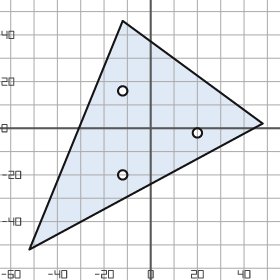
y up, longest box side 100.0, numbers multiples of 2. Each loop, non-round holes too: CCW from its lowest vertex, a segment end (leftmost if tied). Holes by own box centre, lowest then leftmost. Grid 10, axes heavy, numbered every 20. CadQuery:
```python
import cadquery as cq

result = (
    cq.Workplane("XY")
    .moveTo(-52.0, -52.0)
    .lineTo(48.0, 2.0)
    .lineTo(-12.0, 46.0)
    .close()
    .moveTo(-12.0, -20.0)
    .circle(2.0)
    .moveTo(20.0, -2.0)
    .circle(2.0)
    .moveTo(-12.0, 16.0)
    .circle(2.0)
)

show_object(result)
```